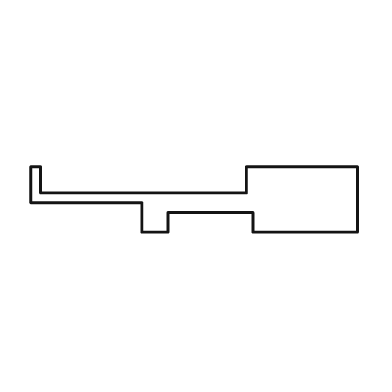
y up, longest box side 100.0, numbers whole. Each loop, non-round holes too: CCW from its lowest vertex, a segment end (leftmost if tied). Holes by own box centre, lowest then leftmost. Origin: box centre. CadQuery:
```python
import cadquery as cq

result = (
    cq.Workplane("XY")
    .moveTo(-16.0, -10.0)
    .lineTo(-8.0, -10.0)
    .lineTo(-8.0, -4.0)
    .lineTo(18.0, -4.0)
    .lineTo(18.0, -10.0)
    .lineTo(50.0, -10.0)
    .lineTo(50.0, 10.0)
    .lineTo(16.0, 10.0)
    .lineTo(16.0, 2.0)
    .lineTo(-47.0, 2.0)
    .lineTo(-47.0, 10.0)
    .lineTo(-50.0, 10.0)
    .lineTo(-50.0, -1.0)
    .lineTo(-16.0, -1.0)
    .close()
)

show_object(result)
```